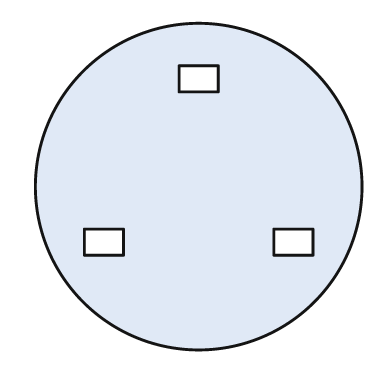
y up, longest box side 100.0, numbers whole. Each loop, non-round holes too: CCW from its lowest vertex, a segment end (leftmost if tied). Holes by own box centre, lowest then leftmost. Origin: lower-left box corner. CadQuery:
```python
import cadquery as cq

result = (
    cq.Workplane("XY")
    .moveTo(50.0, 50.0)
    .circle(50.0)
    .moveTo(15.0, 29.0)
    .lineTo(27.0, 29.0)
    .lineTo(27.0, 37.0)
    .lineTo(15.0, 37.0)
    .close()
    .moveTo(73.0, 29.0)
    .lineTo(85.0, 29.0)
    .lineTo(85.0, 37.0)
    .lineTo(73.0, 37.0)
    .close()
    .moveTo(44.0, 79.0)
    .lineTo(56.0, 79.0)
    .lineTo(56.0, 87.0)
    .lineTo(44.0, 87.0)
    .close()
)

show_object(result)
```